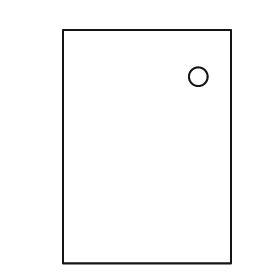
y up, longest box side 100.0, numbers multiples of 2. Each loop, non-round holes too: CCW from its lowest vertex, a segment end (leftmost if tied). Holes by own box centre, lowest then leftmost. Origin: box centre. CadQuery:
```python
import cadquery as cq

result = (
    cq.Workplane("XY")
    .moveTo(-36.0, -50.0)
    .lineTo(36.0, -50.0)
    .lineTo(36.0, 50.0)
    .lineTo(-36.0, 50.0)
    .close()
    .moveTo(22.0, 30.0)
    .circle(4.0)
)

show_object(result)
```